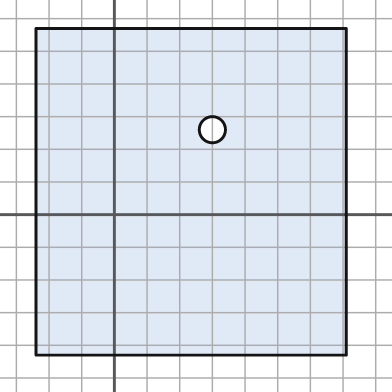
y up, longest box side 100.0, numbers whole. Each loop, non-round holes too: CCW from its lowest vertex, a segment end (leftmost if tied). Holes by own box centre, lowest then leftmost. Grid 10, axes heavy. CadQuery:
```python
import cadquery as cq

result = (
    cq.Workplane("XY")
    .moveTo(-24.0, -43.0)
    .lineTo(71.0, -43.0)
    .lineTo(71.0, 57.0)
    .lineTo(-24.0, 57.0)
    .close()
    .moveTo(30.0, 26.0)
    .circle(4.0)
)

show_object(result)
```